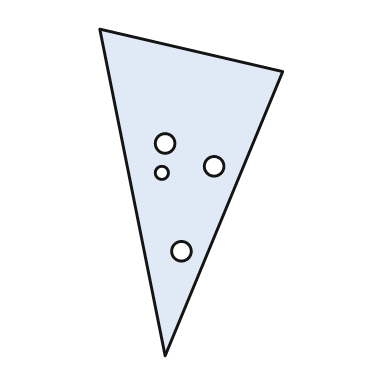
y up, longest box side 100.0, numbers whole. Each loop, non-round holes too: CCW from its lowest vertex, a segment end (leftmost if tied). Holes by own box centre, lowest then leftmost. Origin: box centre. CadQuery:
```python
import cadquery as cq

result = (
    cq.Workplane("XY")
    .moveTo(-8.0, -50.0)
    .lineTo(28.0, 37.0)
    .lineTo(-28.0, 50.0)
    .close()
    .moveTo(-3.0, -18.0)
    .circle(3.0)
    .moveTo(-9.0, 6.0)
    .circle(2.0)
    .moveTo(7.0, 8.0)
    .circle(3.0)
    .moveTo(-8.0, 15.0)
    .circle(3.0)
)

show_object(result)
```